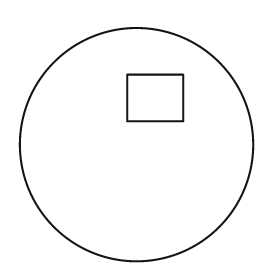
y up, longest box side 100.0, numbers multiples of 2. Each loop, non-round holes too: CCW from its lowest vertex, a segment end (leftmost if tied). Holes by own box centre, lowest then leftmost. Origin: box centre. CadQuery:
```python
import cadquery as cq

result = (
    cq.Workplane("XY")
    .moveTo(0.0, 0.0)
    .circle(50.0)
    .moveTo(-4.0, 10.0)
    .lineTo(20.0, 10.0)
    .lineTo(20.0, 30.0)
    .lineTo(-4.0, 30.0)
    .close()
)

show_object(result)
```